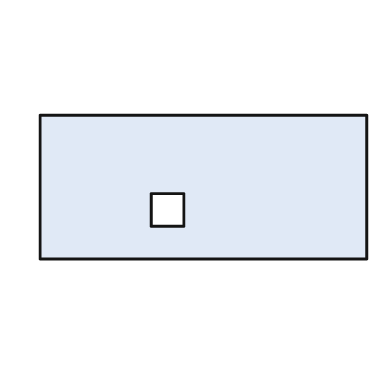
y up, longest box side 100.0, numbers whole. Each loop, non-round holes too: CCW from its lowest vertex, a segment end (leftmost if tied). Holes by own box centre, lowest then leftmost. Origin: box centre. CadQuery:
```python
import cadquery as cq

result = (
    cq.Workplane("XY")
    .moveTo(-50.0, -22.0)
    .lineTo(50.0, -22.0)
    .lineTo(50.0, 22.0)
    .lineTo(-50.0, 22.0)
    .close()
    .moveTo(-16.0, -12.0)
    .lineTo(-6.0, -12.0)
    .lineTo(-6.0, -2.0)
    .lineTo(-16.0, -2.0)
    .close()
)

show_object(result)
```